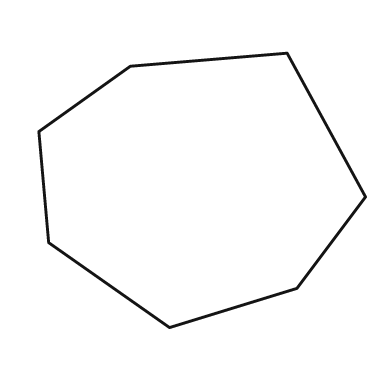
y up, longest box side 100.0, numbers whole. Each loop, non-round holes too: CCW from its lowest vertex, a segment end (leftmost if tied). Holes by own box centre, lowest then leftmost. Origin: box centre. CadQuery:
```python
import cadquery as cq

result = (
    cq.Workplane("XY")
    .moveTo(-10.0, -42.0)
    .lineTo(29.0, -30.0)
    .lineTo(50.0, -2.0)
    .lineTo(26.0, 42.0)
    .lineTo(-22.0, 38.0)
    .lineTo(-50.0, 18.0)
    .lineTo(-47.0, -16.0)
    .close()
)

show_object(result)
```